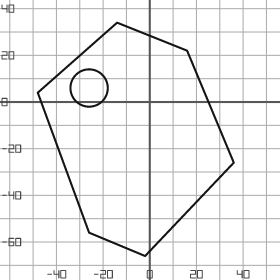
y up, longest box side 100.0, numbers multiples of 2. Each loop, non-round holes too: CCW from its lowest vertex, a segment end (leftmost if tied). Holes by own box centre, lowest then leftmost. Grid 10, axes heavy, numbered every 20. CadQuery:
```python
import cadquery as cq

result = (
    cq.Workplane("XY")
    .moveTo(-2.0, -66.0)
    .lineTo(36.0, -26.0)
    .lineTo(16.0, 22.0)
    .lineTo(-14.0, 34.0)
    .lineTo(-48.0, 4.0)
    .lineTo(-26.0, -56.0)
    .close()
    .moveTo(-26.0, 6.0)
    .circle(8.0)
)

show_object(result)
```